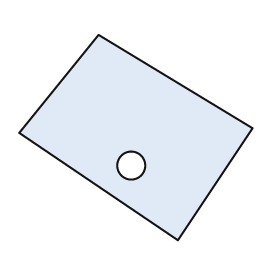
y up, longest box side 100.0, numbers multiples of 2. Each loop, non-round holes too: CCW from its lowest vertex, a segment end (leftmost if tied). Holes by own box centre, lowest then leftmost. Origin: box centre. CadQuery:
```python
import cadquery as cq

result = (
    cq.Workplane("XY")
    .moveTo(18.0, -44.0)
    .lineTo(50.0, 4.0)
    .lineTo(-16.0, 44.0)
    .lineTo(-50.0, 2.0)
    .close()
    .moveTo(-2.0, -12.0)
    .circle(6.0)
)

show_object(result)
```